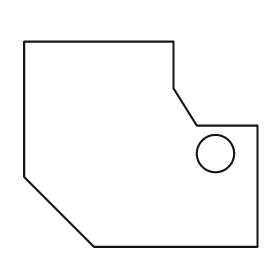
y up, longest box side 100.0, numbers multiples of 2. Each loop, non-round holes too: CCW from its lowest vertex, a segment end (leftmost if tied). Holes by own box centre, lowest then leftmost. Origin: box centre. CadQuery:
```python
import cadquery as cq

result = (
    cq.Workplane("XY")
    .moveTo(-20.0, -44.0)
    .lineTo(50.0, -44.0)
    .lineTo(50.0, 8.0)
    .lineTo(24.0, 8.0)
    .lineTo(14.0, 24.0)
    .lineTo(14.0, 44.0)
    .lineTo(-50.0, 44.0)
    .lineTo(-50.0, -14.0)
    .close()
    .moveTo(32.0, -4.0)
    .circle(8.0)
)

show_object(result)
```